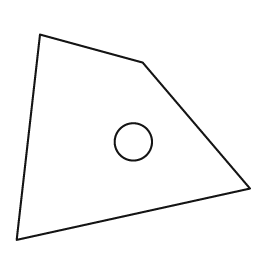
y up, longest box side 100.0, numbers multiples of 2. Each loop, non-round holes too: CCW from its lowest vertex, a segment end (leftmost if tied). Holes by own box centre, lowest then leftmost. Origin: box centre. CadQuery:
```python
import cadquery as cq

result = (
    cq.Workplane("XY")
    .moveTo(-50.0, -44.0)
    .lineTo(50.0, -22.0)
    .lineTo(4.0, 32.0)
    .lineTo(-40.0, 44.0)
    .close()
    .moveTo(0.0, -2.0)
    .circle(8.0)
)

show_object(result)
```